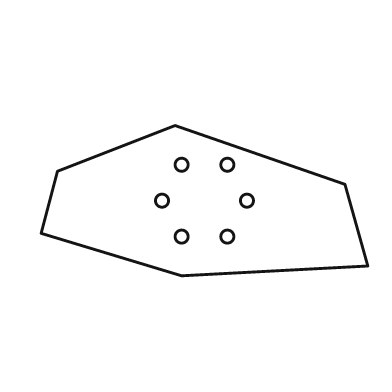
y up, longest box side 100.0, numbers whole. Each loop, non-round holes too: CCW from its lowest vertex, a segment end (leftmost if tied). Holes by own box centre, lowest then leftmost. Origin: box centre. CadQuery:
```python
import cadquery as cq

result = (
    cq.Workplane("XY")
    .moveTo(-7.0, -23.0)
    .lineTo(50.0, -20.0)
    .lineTo(43.0, 5.0)
    .lineTo(-9.0, 23.0)
    .lineTo(-45.0, 9.0)
    .lineTo(-50.0, -10.0)
    .close()
    .moveTo(-7.0, -11.0)
    .circle(2.0)
    .moveTo(7.0, -11.0)
    .circle(2.0)
    .moveTo(-13.0, 0.0)
    .circle(2.0)
    .moveTo(13.0, 0.0)
    .circle(2.0)
    .moveTo(-7.0, 11.0)
    .circle(2.0)
    .moveTo(7.0, 11.0)
    .circle(2.0)
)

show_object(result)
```